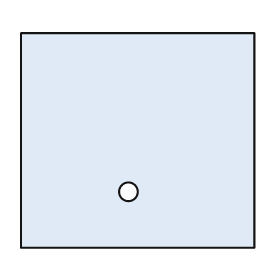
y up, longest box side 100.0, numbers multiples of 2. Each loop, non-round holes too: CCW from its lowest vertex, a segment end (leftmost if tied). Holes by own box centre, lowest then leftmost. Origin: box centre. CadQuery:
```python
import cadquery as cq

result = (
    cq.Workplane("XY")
    .moveTo(-50.0, -46.0)
    .lineTo(50.0, -46.0)
    .lineTo(50.0, 46.0)
    .lineTo(-50.0, 46.0)
    .close()
    .moveTo(-4.0, -22.0)
    .circle(4.0)
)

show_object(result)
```